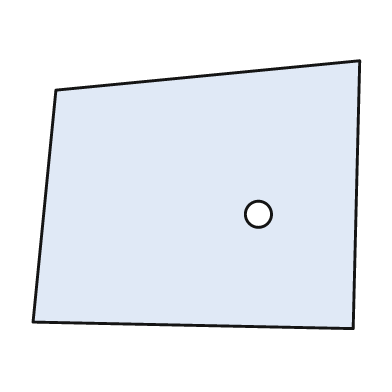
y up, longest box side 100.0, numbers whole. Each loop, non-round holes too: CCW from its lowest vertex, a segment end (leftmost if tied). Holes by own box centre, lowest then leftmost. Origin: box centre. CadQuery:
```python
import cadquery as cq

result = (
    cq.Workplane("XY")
    .moveTo(48.0, -41.0)
    .lineTo(50.0, 41.0)
    .lineTo(-43.0, 32.0)
    .lineTo(-50.0, -39.0)
    .close()
    .moveTo(19.0, -6.0)
    .circle(4.0)
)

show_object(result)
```